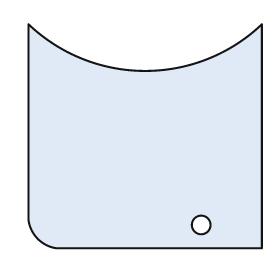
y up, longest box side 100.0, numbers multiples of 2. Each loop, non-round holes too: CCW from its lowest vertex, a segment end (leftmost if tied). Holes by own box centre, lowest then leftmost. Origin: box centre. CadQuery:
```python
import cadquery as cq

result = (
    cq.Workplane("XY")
    .moveTo(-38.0, -48.0)
    .lineTo(50.0, -48.0)
    .lineTo(50.0, 48.0)
    .threePointArc((0.0, 28.0), (-50.0, 48.0))
    .lineTo(-50.0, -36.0)
    .threePointArc((-46.0, -44.0), (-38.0, -48.0))
    .close()
    .moveTo(24.0, -38.0)
    .circle(4.0)
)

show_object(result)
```